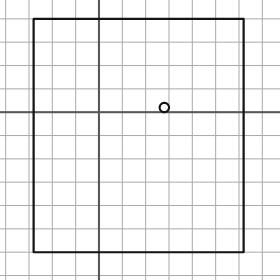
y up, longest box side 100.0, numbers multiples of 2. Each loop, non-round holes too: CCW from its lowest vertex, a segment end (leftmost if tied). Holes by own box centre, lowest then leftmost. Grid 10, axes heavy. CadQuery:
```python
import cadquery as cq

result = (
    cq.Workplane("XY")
    .moveTo(-28.0, -60.0)
    .lineTo(62.0, -60.0)
    .lineTo(62.0, 40.0)
    .lineTo(-28.0, 40.0)
    .close()
    .moveTo(28.0, 2.0)
    .circle(2.0)
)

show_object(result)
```